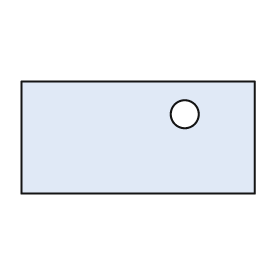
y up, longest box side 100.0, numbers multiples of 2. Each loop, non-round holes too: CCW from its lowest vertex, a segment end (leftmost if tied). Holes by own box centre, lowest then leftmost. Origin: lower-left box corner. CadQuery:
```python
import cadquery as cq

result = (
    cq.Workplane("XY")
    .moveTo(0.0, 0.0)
    .lineTo(100.0, 0.0)
    .lineTo(100.0, 48.0)
    .lineTo(0.0, 48.0)
    .close()
    .moveTo(70.0, 34.0)
    .circle(6.0)
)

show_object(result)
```